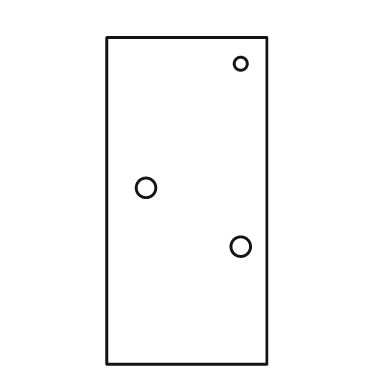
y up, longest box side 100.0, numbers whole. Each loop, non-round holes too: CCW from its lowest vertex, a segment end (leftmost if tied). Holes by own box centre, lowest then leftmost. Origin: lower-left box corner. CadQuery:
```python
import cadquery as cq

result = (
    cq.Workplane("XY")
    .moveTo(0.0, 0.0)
    .lineTo(49.0, 0.0)
    .lineTo(49.0, 100.0)
    .lineTo(0.0, 100.0)
    .close()
    .moveTo(41.0, 36.0)
    .circle(3.0)
    .moveTo(12.0, 54.0)
    .circle(3.0)
    .moveTo(41.0, 92.0)
    .circle(2.0)
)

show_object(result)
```